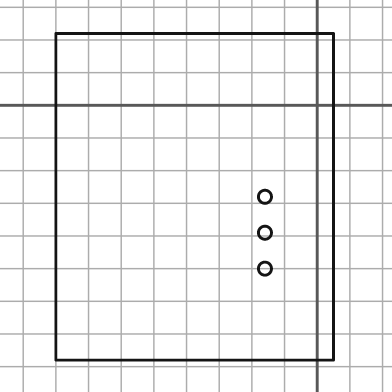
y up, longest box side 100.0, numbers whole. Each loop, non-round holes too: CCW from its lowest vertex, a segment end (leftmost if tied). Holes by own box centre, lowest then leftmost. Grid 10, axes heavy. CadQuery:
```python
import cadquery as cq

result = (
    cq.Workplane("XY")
    .moveTo(-80.0, -78.0)
    .lineTo(5.0, -78.0)
    .lineTo(5.0, 22.0)
    .lineTo(-80.0, 22.0)
    .close()
    .moveTo(-16.0, -50.0)
    .circle(2.0)
    .moveTo(-16.0, -39.0)
    .circle(2.0)
    .moveTo(-16.0, -28.0)
    .circle(2.0)
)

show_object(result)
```